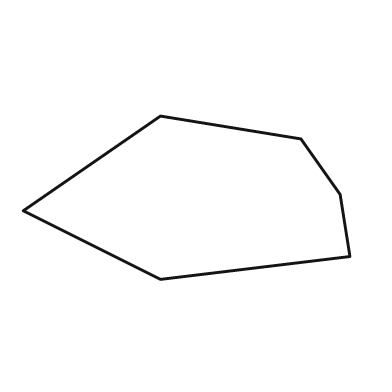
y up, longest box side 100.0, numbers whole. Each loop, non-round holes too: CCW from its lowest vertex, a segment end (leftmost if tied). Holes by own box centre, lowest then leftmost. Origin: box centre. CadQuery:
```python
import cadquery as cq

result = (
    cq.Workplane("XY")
    .moveTo(-8.0, -25.0)
    .lineTo(50.0, -18.0)
    .lineTo(47.0, 1.0)
    .lineTo(35.0, 18.0)
    .lineTo(-8.0, 25.0)
    .lineTo(-50.0, -4.0)
    .close()
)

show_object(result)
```